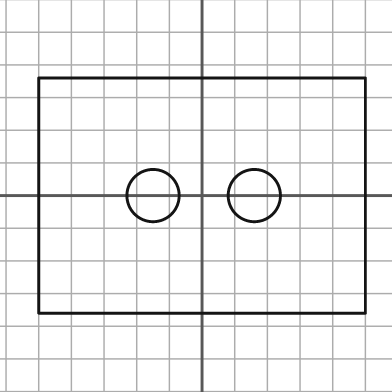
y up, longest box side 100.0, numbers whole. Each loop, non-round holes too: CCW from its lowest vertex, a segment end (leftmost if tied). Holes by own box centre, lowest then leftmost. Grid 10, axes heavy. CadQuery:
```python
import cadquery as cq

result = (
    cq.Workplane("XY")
    .moveTo(-50.0, -36.0)
    .lineTo(50.0, -36.0)
    .lineTo(50.0, 36.0)
    .lineTo(-50.0, 36.0)
    .close()
    .moveTo(-15.0, 0.0)
    .circle(8.0)
    .moveTo(16.0, 0.0)
    .circle(8.0)
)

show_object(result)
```